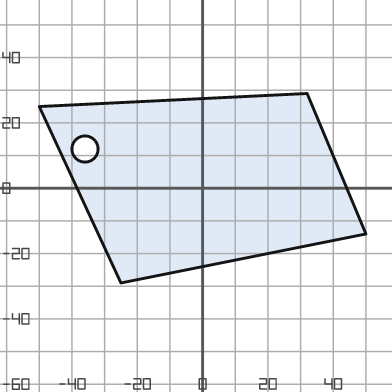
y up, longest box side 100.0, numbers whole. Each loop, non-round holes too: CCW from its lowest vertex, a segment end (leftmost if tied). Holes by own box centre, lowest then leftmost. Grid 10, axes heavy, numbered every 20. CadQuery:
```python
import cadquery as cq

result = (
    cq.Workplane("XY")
    .moveTo(-25.0, -29.0)
    .lineTo(50.0, -14.0)
    .lineTo(32.0, 29.0)
    .lineTo(-50.0, 25.0)
    .close()
    .moveTo(-36.0, 12.0)
    .circle(4.0)
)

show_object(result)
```